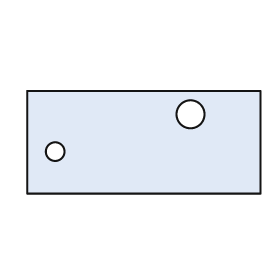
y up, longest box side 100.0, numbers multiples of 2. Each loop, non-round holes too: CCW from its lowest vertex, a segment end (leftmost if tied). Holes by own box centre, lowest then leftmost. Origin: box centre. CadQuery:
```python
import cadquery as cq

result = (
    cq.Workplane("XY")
    .moveTo(-50.0, -22.0)
    .lineTo(50.0, -22.0)
    .lineTo(50.0, 22.0)
    .lineTo(-50.0, 22.0)
    .close()
    .moveTo(-38.0, -4.0)
    .circle(4.0)
    .moveTo(20.0, 12.0)
    .circle(6.0)
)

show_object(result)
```